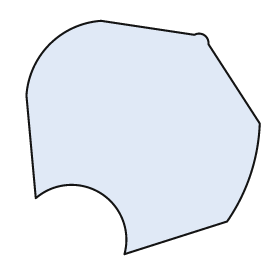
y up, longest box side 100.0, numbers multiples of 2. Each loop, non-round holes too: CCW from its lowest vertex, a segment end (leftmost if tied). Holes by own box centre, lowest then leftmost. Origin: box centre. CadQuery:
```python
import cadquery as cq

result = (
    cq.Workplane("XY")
    .moveTo(-8.0, -50.0)
    .lineTo(36.0, -36.0)
    .threePointArc((46.0, -16.0), (50.0, 6.0))
    .lineTo(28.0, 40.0)
    .threePointArc((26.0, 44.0), (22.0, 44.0))
    .lineTo(-18.0, 50.0)
    .threePointArc((-40.0, 40.0), (-50.0, 18.0))
    .lineTo(-46.0, -26.0)
    .threePointArc((-18.0, -24.0), (-8.0, -50.0))
    .close()
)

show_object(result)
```